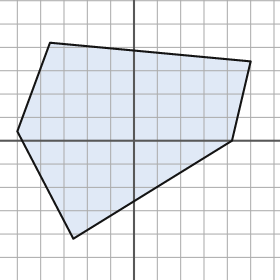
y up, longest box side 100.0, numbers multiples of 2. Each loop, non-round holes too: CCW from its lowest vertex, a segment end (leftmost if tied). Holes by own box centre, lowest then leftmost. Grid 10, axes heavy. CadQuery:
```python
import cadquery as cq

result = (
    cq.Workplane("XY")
    .moveTo(-26.0, -42.0)
    .lineTo(42.0, 0.0)
    .lineTo(50.0, 34.0)
    .lineTo(-36.0, 42.0)
    .lineTo(-50.0, 4.0)
    .close()
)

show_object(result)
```